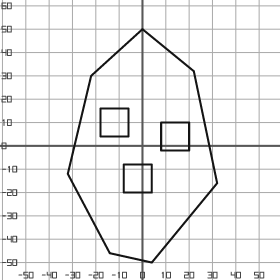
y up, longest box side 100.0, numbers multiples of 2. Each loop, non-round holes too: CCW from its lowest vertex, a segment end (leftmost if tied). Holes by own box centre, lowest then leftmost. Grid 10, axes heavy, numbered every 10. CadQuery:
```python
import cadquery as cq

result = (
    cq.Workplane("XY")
    .moveTo(4.0, -50.0)
    .lineTo(32.0, -16.0)
    .lineTo(22.0, 32.0)
    .lineTo(0.0, 50.0)
    .lineTo(-22.0, 30.0)
    .lineTo(-32.0, -12.0)
    .lineTo(-14.0, -46.0)
    .close()
    .moveTo(-8.0, -20.0)
    .lineTo(4.0, -20.0)
    .lineTo(4.0, -8.0)
    .lineTo(-8.0, -8.0)
    .close()
    .moveTo(8.0, -2.0)
    .lineTo(20.0, -2.0)
    .lineTo(20.0, 10.0)
    .lineTo(8.0, 10.0)
    .close()
    .moveTo(-18.0, 4.0)
    .lineTo(-6.0, 4.0)
    .lineTo(-6.0, 16.0)
    .lineTo(-18.0, 16.0)
    .close()
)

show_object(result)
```